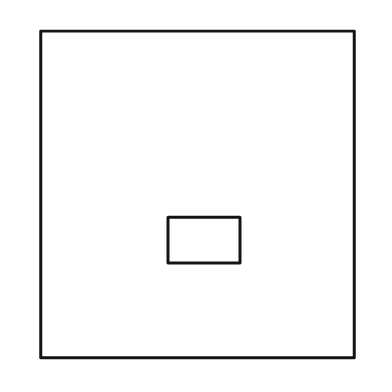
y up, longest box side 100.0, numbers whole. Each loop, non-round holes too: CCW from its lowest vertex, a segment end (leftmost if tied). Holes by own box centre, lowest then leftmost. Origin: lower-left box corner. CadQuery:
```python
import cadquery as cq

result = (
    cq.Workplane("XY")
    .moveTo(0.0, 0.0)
    .lineTo(96.0, 0.0)
    .lineTo(96.0, 100.0)
    .lineTo(0.0, 100.0)
    .close()
    .moveTo(39.0, 29.0)
    .lineTo(61.0, 29.0)
    .lineTo(61.0, 43.0)
    .lineTo(39.0, 43.0)
    .close()
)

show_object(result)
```